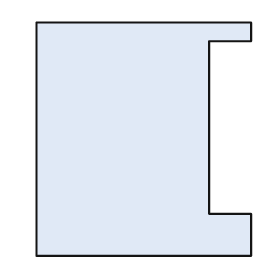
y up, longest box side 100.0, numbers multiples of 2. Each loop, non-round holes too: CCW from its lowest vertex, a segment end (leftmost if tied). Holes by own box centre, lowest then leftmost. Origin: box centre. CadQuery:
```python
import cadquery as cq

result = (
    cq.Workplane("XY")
    .moveTo(-46.0, -50.0)
    .lineTo(46.0, -50.0)
    .lineTo(46.0, -32.0)
    .lineTo(28.0, -32.0)
    .lineTo(28.0, 42.0)
    .lineTo(46.0, 42.0)
    .lineTo(46.0, 50.0)
    .lineTo(-46.0, 50.0)
    .close()
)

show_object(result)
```